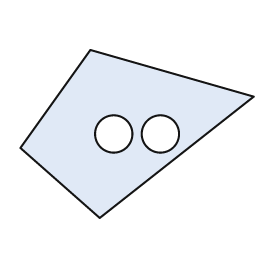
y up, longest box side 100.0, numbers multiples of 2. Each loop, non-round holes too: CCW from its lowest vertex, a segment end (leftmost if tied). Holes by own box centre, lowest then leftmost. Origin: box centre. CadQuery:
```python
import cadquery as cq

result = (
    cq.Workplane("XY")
    .moveTo(-16.0, -36.0)
    .lineTo(50.0, 16.0)
    .lineTo(-20.0, 36.0)
    .lineTo(-50.0, -6.0)
    .close()
    .moveTo(-10.0, 0.0)
    .circle(8.0)
    .moveTo(10.0, 0.0)
    .circle(8.0)
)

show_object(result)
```